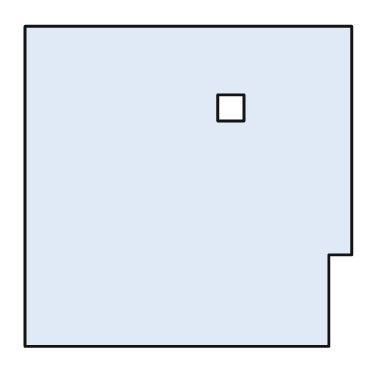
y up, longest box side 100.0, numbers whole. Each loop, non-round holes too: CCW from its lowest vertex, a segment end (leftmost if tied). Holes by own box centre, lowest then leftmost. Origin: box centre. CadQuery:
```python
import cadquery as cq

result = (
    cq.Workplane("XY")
    .moveTo(-50.0, -49.0)
    .lineTo(43.0, -49.0)
    .lineTo(43.0, -21.0)
    .lineTo(50.0, -21.0)
    .lineTo(50.0, 49.0)
    .lineTo(-50.0, 49.0)
    .close()
    .moveTo(9.0, 20.0)
    .lineTo(17.0, 20.0)
    .lineTo(17.0, 28.0)
    .lineTo(9.0, 28.0)
    .close()
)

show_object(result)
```